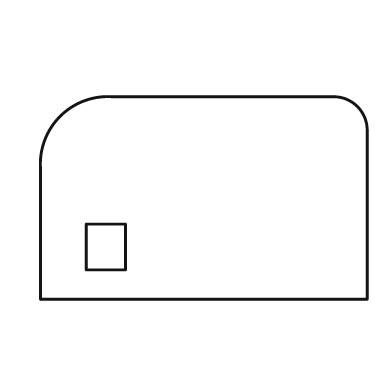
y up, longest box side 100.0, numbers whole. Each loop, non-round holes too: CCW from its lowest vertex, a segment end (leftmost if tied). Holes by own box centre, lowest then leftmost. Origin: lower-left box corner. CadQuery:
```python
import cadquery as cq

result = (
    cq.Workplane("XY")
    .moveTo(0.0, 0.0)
    .lineTo(100.0, 0.0)
    .lineTo(100.0, 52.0)
    .threePointArc((97.0, 59.0), (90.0, 62.0))
    .lineTo(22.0, 62.0)
    .threePointArc((6.0, 56.0), (0.0, 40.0))
    .close()
    .moveTo(14.0, 9.0)
    .lineTo(26.0, 9.0)
    .lineTo(26.0, 23.0)
    .lineTo(14.0, 23.0)
    .close()
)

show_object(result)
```